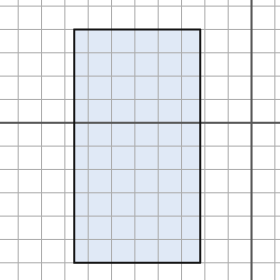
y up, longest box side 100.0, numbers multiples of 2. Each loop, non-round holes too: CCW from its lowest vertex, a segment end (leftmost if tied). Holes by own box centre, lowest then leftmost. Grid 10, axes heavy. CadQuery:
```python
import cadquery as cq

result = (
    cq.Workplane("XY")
    .moveTo(-76.0, -60.0)
    .lineTo(-22.0, -60.0)
    .lineTo(-22.0, 40.0)
    .lineTo(-76.0, 40.0)
    .close()
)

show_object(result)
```